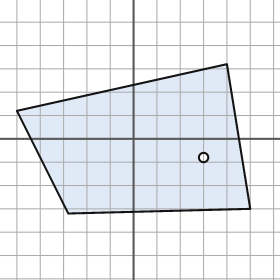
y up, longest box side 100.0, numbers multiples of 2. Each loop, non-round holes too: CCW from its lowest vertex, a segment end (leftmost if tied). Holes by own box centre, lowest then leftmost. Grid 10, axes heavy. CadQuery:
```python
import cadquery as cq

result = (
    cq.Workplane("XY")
    .moveTo(-28.0, -32.0)
    .lineTo(50.0, -30.0)
    .lineTo(40.0, 32.0)
    .lineTo(-50.0, 12.0)
    .close()
    .moveTo(30.0, -8.0)
    .circle(2.0)
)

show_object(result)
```